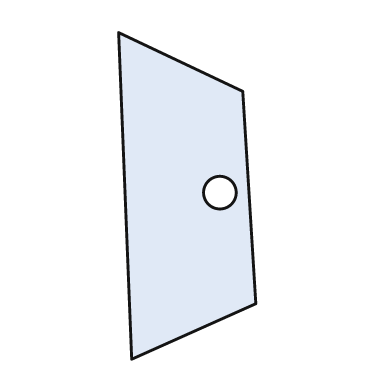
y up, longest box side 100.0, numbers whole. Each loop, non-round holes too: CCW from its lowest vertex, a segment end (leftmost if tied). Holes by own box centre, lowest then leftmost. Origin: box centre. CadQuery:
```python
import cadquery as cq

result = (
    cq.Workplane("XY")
    .moveTo(-17.0, -50.0)
    .lineTo(21.0, -33.0)
    .lineTo(17.0, 32.0)
    .lineTo(-21.0, 50.0)
    .close()
    .moveTo(10.0, 1.0)
    .circle(5.0)
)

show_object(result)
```